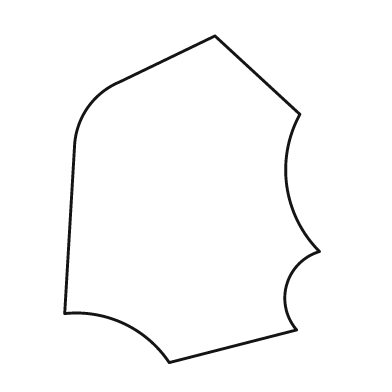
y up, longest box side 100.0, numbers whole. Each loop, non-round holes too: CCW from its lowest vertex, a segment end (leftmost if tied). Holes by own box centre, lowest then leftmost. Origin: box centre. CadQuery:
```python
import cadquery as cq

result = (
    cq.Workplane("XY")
    .moveTo(-7.0, -50.0)
    .lineTo(32.0, -40.0)
    .threePointArc((29.0, -26.0), (39.0, -16.0))
    .threePointArc((29.0, 4.0), (33.0, 26.0))
    .lineTo(7.0, 50.0)
    .lineTo(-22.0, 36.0)
    .threePointArc((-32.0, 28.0), (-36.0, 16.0))
    .lineTo(-39.0, -35.0)
    .threePointArc((-21.0, -38.0), (-7.0, -50.0))
    .close()
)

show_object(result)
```